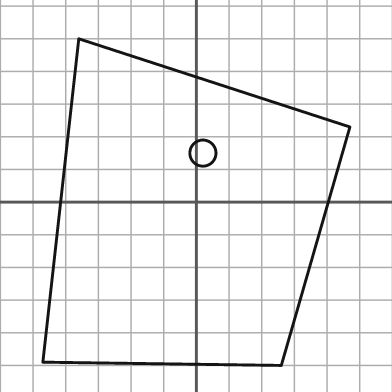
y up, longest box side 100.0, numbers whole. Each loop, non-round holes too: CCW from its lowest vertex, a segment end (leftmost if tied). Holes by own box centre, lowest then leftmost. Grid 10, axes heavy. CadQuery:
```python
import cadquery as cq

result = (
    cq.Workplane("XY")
    .moveTo(26.0, -50.0)
    .lineTo(47.0, 23.0)
    .lineTo(-36.0, 50.0)
    .lineTo(-47.0, -49.0)
    .close()
    .moveTo(2.0, 15.0)
    .circle(4.0)
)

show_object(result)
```